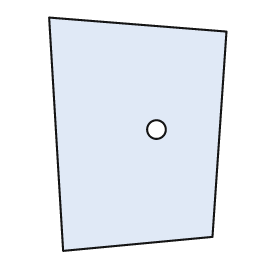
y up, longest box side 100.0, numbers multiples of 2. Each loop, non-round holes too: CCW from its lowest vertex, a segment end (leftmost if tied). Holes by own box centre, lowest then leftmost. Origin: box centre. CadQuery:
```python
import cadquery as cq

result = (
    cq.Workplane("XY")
    .moveTo(-32.0, -50.0)
    .lineTo(32.0, -44.0)
    .lineTo(38.0, 44.0)
    .lineTo(-38.0, 50.0)
    .close()
    .moveTo(8.0, 2.0)
    .circle(4.0)
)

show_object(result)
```